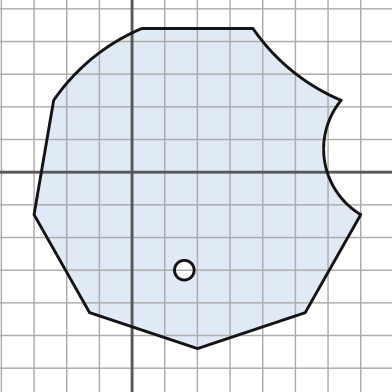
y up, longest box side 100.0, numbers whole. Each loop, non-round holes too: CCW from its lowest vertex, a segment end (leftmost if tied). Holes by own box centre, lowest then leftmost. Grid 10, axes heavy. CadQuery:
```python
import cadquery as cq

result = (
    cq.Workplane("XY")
    .moveTo(20.0, -54.0)
    .lineTo(53.0, -43.0)
    .lineTo(70.0, -13.0)
    .threePointArc((59.0, 3.0), (64.0, 22.0))
    .threePointArc((49.0, 31.0), (37.0, 44.0))
    .lineTo(3.0, 44.0)
    .threePointArc((-12.0, 35.0), (-24.0, 22.0))
    .lineTo(-30.0, -13.0)
    .lineTo(-13.0, -43.0)
    .close()
    .moveTo(16.0, -30.0)
    .circle(3.0)
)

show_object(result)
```